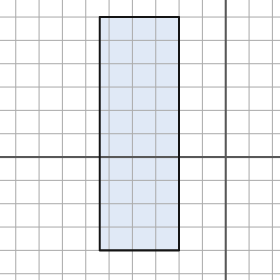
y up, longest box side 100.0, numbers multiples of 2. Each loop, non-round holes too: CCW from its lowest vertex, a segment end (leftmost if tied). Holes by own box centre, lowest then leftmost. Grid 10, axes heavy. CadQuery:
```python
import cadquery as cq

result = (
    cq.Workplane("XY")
    .moveTo(-54.0, -40.0)
    .lineTo(-20.0, -40.0)
    .lineTo(-20.0, 60.0)
    .lineTo(-54.0, 60.0)
    .close()
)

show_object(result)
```